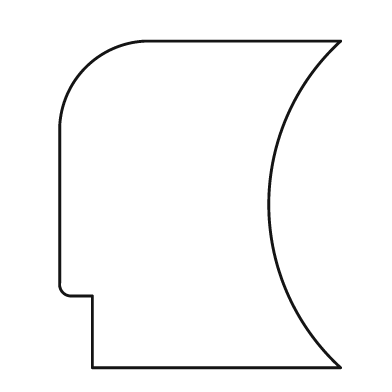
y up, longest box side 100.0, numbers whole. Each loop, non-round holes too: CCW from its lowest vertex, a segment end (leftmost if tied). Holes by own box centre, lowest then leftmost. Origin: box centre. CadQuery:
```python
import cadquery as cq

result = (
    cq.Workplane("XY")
    .moveTo(-33.0, -50.0)
    .lineTo(43.0, -50.0)
    .threePointArc((21.0, 0.0), (43.0, 50.0))
    .lineTo(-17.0, 50.0)
    .threePointArc((-35.0, 42.0), (-43.0, 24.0))
    .lineTo(-43.0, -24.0)
    .threePointArc((-42.0, -27.0), (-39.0, -28.0))
    .lineTo(-33.0, -28.0)
    .close()
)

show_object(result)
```